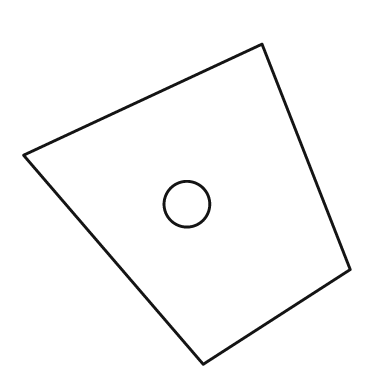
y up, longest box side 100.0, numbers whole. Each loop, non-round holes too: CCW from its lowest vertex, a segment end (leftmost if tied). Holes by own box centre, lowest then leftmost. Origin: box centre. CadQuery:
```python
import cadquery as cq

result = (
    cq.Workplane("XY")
    .moveTo(5.0, -49.0)
    .lineTo(50.0, -20.0)
    .lineTo(23.0, 49.0)
    .lineTo(-50.0, 15.0)
    .close()
    .moveTo(0.0, 0.0)
    .circle(7.0)
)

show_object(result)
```